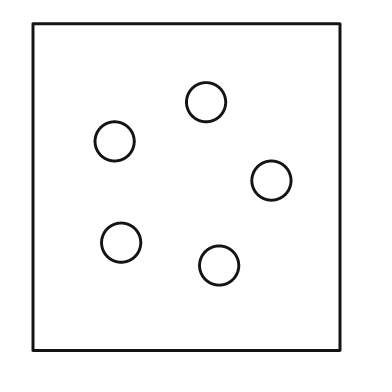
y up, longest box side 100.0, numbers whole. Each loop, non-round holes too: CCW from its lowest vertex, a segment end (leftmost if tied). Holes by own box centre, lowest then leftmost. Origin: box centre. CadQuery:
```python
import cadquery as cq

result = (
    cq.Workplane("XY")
    .moveTo(-47.0, -50.0)
    .lineTo(47.0, -50.0)
    .lineTo(47.0, 50.0)
    .lineTo(-47.0, 50.0)
    .close()
    .moveTo(10.0, -24.0)
    .circle(6.0)
    .moveTo(-20.0, -17.0)
    .circle(6.0)
    .moveTo(26.0, 2.0)
    .circle(6.0)
    .moveTo(-22.0, 14.0)
    .circle(6.0)
    .moveTo(6.0, 26.0)
    .circle(6.0)
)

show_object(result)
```